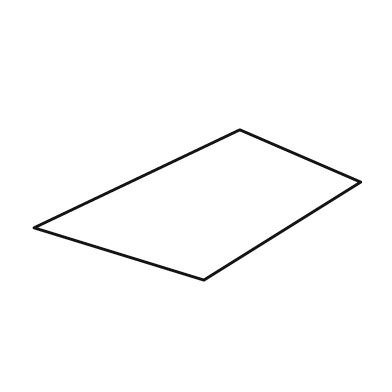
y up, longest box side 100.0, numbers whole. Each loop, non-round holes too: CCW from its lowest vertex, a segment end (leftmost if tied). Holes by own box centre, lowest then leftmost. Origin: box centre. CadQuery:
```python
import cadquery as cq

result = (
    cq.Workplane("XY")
    .moveTo(2.0, -23.0)
    .lineTo(50.0, 7.0)
    .lineTo(13.0, 23.0)
    .lineTo(-50.0, -7.0)
    .close()
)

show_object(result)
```